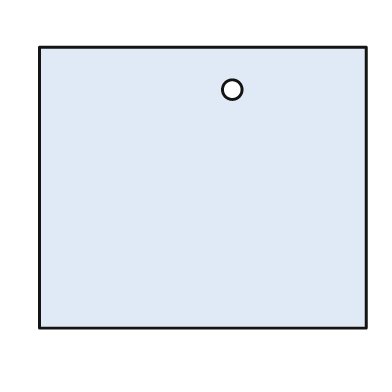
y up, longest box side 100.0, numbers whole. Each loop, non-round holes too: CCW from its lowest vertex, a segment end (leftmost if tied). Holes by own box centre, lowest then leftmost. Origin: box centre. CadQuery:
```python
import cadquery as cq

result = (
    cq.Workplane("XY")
    .moveTo(-50.0, -43.0)
    .lineTo(50.0, -43.0)
    .lineTo(50.0, 43.0)
    .lineTo(-50.0, 43.0)
    .close()
    .moveTo(9.0, 30.0)
    .circle(3.0)
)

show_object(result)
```